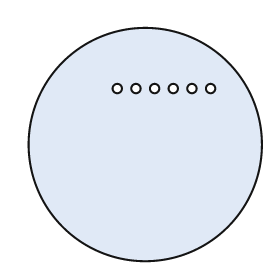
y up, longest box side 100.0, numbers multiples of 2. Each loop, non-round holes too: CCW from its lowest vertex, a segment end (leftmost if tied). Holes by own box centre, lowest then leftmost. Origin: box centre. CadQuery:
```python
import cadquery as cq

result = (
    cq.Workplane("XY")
    .moveTo(0.0, 0.0)
    .circle(50.0)
    .moveTo(-12.0, 24.0)
    .circle(2.0)
    .moveTo(-4.0, 24.0)
    .circle(2.0)
    .moveTo(4.0, 24.0)
    .circle(2.0)
    .moveTo(12.0, 24.0)
    .circle(2.0)
    .moveTo(20.0, 24.0)
    .circle(2.0)
    .moveTo(28.0, 24.0)
    .circle(2.0)
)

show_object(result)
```